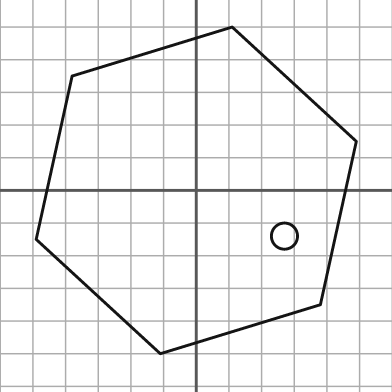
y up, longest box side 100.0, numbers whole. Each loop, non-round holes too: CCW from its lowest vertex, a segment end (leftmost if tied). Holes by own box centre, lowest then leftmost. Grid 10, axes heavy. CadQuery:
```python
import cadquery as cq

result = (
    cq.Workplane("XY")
    .moveTo(-11.0, -50.0)
    .lineTo(38.0, -35.0)
    .lineTo(49.0, 15.0)
    .lineTo(11.0, 50.0)
    .lineTo(-38.0, 35.0)
    .lineTo(-49.0, -15.0)
    .close()
    .moveTo(27.0, -14.0)
    .circle(4.0)
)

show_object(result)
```